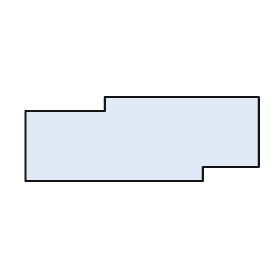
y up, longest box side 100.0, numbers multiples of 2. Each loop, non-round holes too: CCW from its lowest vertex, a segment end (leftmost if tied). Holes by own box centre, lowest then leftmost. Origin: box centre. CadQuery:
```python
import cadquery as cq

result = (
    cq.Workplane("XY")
    .moveTo(-50.0, -18.0)
    .lineTo(26.0, -18.0)
    .lineTo(26.0, -12.0)
    .lineTo(50.0, -12.0)
    .lineTo(50.0, 18.0)
    .lineTo(-16.0, 18.0)
    .lineTo(-16.0, 12.0)
    .lineTo(-50.0, 12.0)
    .close()
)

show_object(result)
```